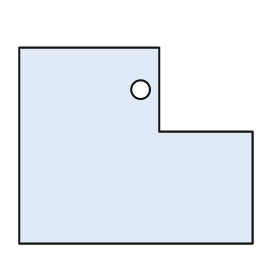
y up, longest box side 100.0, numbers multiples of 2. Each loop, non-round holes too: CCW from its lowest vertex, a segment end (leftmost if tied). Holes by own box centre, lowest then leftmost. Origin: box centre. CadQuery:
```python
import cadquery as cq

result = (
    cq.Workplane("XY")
    .moveTo(-50.0, -42.0)
    .lineTo(50.0, -42.0)
    .lineTo(50.0, 6.0)
    .lineTo(10.0, 6.0)
    .lineTo(10.0, 42.0)
    .lineTo(-50.0, 42.0)
    .close()
    .moveTo(2.0, 24.0)
    .circle(4.0)
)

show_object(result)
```